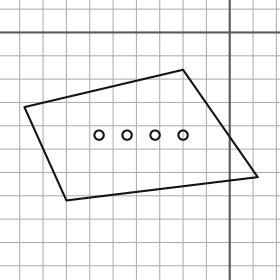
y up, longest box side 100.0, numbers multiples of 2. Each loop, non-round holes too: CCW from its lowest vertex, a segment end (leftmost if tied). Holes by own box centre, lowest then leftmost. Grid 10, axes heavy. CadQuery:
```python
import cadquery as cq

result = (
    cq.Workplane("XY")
    .moveTo(-70.0, -72.0)
    .lineTo(12.0, -62.0)
    .lineTo(-20.0, -16.0)
    .lineTo(-88.0, -32.0)
    .close()
    .moveTo(-56.0, -44.0)
    .circle(2.0)
    .moveTo(-44.0, -44.0)
    .circle(2.0)
    .moveTo(-32.0, -44.0)
    .circle(2.0)
    .moveTo(-20.0, -44.0)
    .circle(2.0)
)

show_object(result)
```